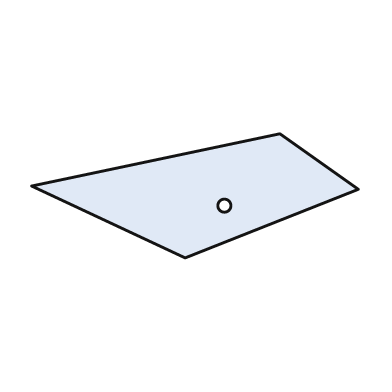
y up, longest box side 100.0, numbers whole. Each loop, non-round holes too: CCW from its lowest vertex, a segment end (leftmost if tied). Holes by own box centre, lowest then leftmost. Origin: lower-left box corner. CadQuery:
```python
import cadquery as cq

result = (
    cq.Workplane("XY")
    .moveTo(47.0, 0.0)
    .lineTo(100.0, 21.0)
    .lineTo(76.0, 38.0)
    .lineTo(0.0, 22.0)
    .close()
    .moveTo(59.0, 16.0)
    .circle(2.0)
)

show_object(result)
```